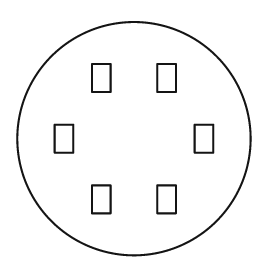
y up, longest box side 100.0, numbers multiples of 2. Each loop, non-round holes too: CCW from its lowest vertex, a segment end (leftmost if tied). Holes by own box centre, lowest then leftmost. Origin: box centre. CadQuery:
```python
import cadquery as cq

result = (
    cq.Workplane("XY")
    .moveTo(0.0, 0.0)
    .circle(50.0)
    .moveTo(-18.0, -32.0)
    .lineTo(-10.0, -32.0)
    .lineTo(-10.0, -20.0)
    .lineTo(-18.0, -20.0)
    .close()
    .moveTo(10.0, -32.0)
    .lineTo(18.0, -32.0)
    .lineTo(18.0, -20.0)
    .lineTo(10.0, -20.0)
    .close()
    .moveTo(-34.0, -6.0)
    .lineTo(-26.0, -6.0)
    .lineTo(-26.0, 6.0)
    .lineTo(-34.0, 6.0)
    .close()
    .moveTo(26.0, -6.0)
    .lineTo(34.0, -6.0)
    .lineTo(34.0, 6.0)
    .lineTo(26.0, 6.0)
    .close()
    .moveTo(-18.0, 20.0)
    .lineTo(-10.0, 20.0)
    .lineTo(-10.0, 32.0)
    .lineTo(-18.0, 32.0)
    .close()
    .moveTo(10.0, 20.0)
    .lineTo(18.0, 20.0)
    .lineTo(18.0, 32.0)
    .lineTo(10.0, 32.0)
    .close()
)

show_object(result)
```